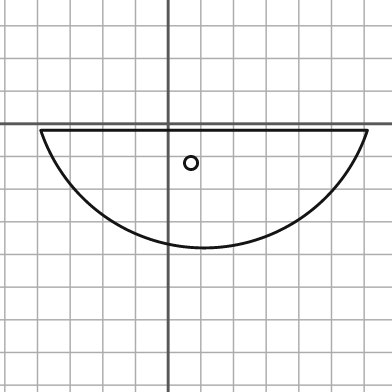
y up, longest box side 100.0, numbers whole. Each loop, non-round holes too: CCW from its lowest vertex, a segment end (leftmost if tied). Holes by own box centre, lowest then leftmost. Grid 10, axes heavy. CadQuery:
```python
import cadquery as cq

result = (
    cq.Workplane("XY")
    .moveTo(-39.0, -2.0)
    .threePointArc((11.0, -38.0), (61.0, -2.0))
    .close()
    .moveTo(7.0, -12.0)
    .circle(2.0)
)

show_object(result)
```